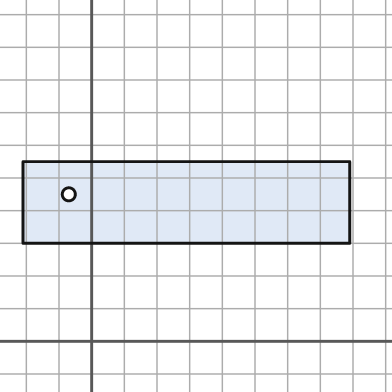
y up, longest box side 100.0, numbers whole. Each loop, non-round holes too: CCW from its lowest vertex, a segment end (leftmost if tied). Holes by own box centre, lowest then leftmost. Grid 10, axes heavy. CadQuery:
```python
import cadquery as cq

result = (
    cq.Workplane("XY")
    .moveTo(-21.0, 30.0)
    .lineTo(79.0, 30.0)
    .lineTo(79.0, 55.0)
    .lineTo(-21.0, 55.0)
    .close()
    .moveTo(-7.0, 45.0)
    .circle(2.0)
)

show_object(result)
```